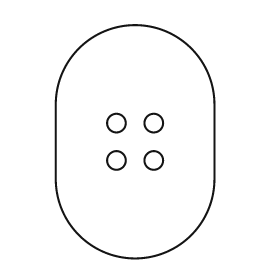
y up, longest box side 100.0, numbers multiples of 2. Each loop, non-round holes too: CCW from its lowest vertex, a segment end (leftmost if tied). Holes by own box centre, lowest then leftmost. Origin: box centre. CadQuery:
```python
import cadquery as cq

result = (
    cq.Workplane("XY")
    .moveTo(-34.0, -16.0)
    .threePointArc((0.0, -50.0), (34.0, -16.0))
    .lineTo(34.0, 16.0)
    .threePointArc((0.0, 50.0), (-34.0, 16.0))
    .close()
    .moveTo(-8.0, -8.0)
    .circle(4.0)
    .moveTo(8.0, -8.0)
    .circle(4.0)
    .moveTo(-8.0, 8.0)
    .circle(4.0)
    .moveTo(8.0, 8.0)
    .circle(4.0)
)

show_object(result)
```